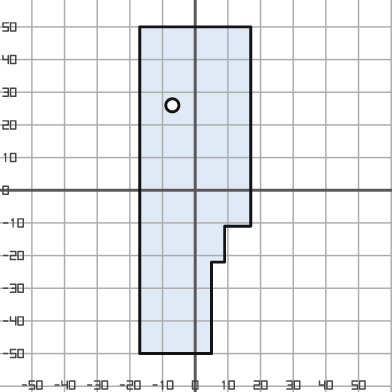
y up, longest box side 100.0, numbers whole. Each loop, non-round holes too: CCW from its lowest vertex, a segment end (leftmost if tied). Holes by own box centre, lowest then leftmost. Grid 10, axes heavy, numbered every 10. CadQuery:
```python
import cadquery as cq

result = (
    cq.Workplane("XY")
    .moveTo(-17.0, -50.0)
    .lineTo(5.0, -50.0)
    .lineTo(5.0, -22.0)
    .lineTo(9.0, -22.0)
    .lineTo(9.0, -11.0)
    .lineTo(17.0, -11.0)
    .lineTo(17.0, 50.0)
    .lineTo(-17.0, 50.0)
    .close()
    .moveTo(-7.0, 26.0)
    .circle(2.0)
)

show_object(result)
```